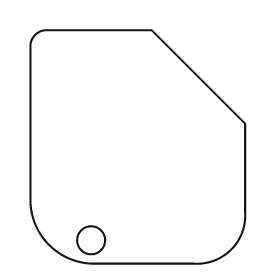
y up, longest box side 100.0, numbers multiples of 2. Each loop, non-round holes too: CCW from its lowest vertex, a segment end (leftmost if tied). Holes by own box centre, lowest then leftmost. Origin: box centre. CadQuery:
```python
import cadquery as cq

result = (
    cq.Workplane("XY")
    .moveTo(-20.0, -50.0)
    .lineTo(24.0, -50.0)
    .threePointArc((40.0, -44.0), (46.0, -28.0))
    .lineTo(46.0, 10.0)
    .lineTo(6.0, 50.0)
    .lineTo(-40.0, 50.0)
    .threePointArc((-44.0, 48.0), (-46.0, 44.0))
    .lineTo(-46.0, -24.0)
    .threePointArc((-38.0, -42.0), (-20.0, -50.0))
    .close()
    .moveTo(-20.0, -40.0)
    .circle(6.0)
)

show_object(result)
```